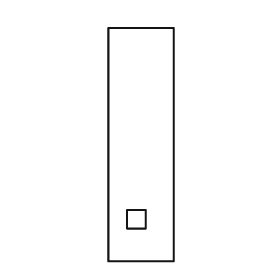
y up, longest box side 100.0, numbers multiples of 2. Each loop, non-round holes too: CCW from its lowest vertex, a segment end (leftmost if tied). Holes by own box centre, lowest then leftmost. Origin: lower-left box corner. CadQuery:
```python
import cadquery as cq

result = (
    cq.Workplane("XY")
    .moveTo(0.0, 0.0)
    .lineTo(28.0, 0.0)
    .lineTo(28.0, 100.0)
    .lineTo(0.0, 100.0)
    .close()
    .moveTo(8.0, 14.0)
    .lineTo(16.0, 14.0)
    .lineTo(16.0, 22.0)
    .lineTo(8.0, 22.0)
    .close()
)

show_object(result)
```